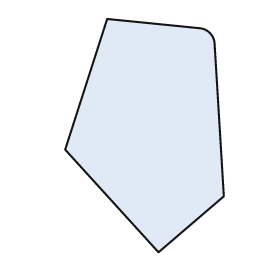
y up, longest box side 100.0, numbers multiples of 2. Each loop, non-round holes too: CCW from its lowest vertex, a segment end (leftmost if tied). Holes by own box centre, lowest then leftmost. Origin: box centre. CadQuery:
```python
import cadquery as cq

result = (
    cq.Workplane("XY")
    .moveTo(6.0, -50.0)
    .lineTo(34.0, -26.0)
    .lineTo(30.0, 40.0)
    .threePointArc((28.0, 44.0), (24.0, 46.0))
    .lineTo(-16.0, 50.0)
    .lineTo(-34.0, -6.0)
    .close()
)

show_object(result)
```